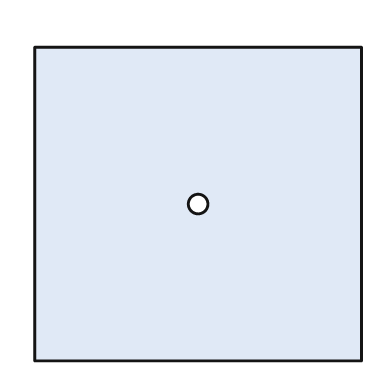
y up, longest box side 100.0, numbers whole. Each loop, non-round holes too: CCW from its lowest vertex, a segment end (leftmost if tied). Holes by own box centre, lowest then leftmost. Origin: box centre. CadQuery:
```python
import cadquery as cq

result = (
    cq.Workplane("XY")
    .moveTo(-50.0, -48.0)
    .lineTo(50.0, -48.0)
    .lineTo(50.0, 48.0)
    .lineTo(-50.0, 48.0)
    .close()
    .moveTo(0.0, 0.0)
    .circle(3.0)
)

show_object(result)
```